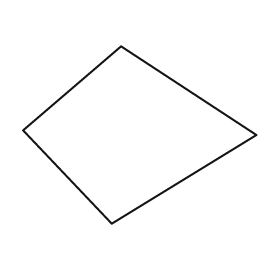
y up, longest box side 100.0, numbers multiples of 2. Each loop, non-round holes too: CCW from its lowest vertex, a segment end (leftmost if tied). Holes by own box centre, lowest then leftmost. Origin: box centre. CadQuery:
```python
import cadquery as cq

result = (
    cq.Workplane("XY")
    .moveTo(-12.0, -38.0)
    .lineTo(50.0, 0.0)
    .lineTo(-8.0, 38.0)
    .lineTo(-50.0, 2.0)
    .close()
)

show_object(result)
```